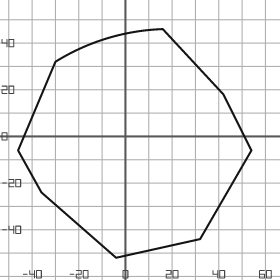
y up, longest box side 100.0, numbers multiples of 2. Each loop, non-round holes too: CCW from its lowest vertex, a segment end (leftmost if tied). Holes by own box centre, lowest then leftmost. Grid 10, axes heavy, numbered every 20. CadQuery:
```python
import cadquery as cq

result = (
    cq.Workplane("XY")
    .moveTo(-4.0, -52.0)
    .lineTo(32.0, -44.0)
    .lineTo(54.0, -6.0)
    .lineTo(42.0, 18.0)
    .lineTo(16.0, 46.0)
    .threePointArc((-8.0, 42.0), (-30.0, 32.0))
    .lineTo(-46.0, -6.0)
    .lineTo(-36.0, -24.0)
    .close()
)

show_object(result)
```